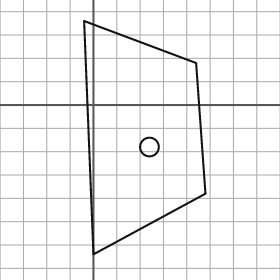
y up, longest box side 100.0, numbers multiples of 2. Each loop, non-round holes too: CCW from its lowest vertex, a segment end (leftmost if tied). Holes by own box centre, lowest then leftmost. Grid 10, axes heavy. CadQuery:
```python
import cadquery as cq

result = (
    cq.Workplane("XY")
    .moveTo(0.0, -64.0)
    .lineTo(48.0, -38.0)
    .lineTo(44.0, 18.0)
    .lineTo(-4.0, 36.0)
    .close()
    .moveTo(24.0, -18.0)
    .circle(4.0)
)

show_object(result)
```